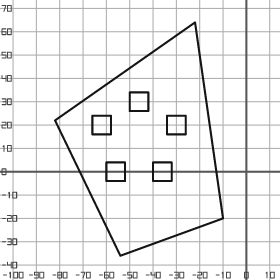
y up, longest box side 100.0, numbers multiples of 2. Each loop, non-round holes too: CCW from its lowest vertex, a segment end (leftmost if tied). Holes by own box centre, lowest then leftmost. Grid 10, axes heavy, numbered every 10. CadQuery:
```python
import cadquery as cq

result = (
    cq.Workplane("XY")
    .moveTo(-54.0, -36.0)
    .lineTo(-10.0, -20.0)
    .lineTo(-22.0, 64.0)
    .lineTo(-82.0, 22.0)
    .close()
    .moveTo(-60.0, -4.0)
    .lineTo(-52.0, -4.0)
    .lineTo(-52.0, 4.0)
    .lineTo(-60.0, 4.0)
    .close()
    .moveTo(-40.0, -4.0)
    .lineTo(-32.0, -4.0)
    .lineTo(-32.0, 4.0)
    .lineTo(-40.0, 4.0)
    .close()
    .moveTo(-66.0, 16.0)
    .lineTo(-58.0, 16.0)
    .lineTo(-58.0, 24.0)
    .lineTo(-66.0, 24.0)
    .close()
    .moveTo(-34.0, 16.0)
    .lineTo(-26.0, 16.0)
    .lineTo(-26.0, 24.0)
    .lineTo(-34.0, 24.0)
    .close()
    .moveTo(-50.0, 26.0)
    .lineTo(-42.0, 26.0)
    .lineTo(-42.0, 34.0)
    .lineTo(-50.0, 34.0)
    .close()
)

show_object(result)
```